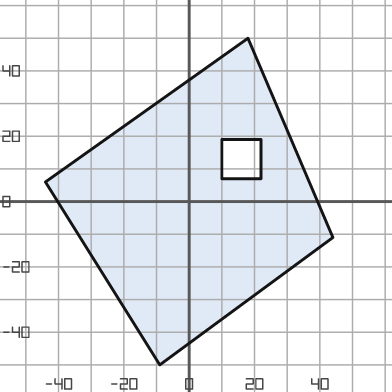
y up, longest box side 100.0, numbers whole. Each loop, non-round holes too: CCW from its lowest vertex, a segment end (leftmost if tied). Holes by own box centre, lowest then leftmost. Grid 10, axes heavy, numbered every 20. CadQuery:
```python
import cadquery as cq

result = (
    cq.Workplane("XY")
    .moveTo(-9.0, -50.0)
    .lineTo(44.0, -11.0)
    .lineTo(18.0, 50.0)
    .lineTo(-44.0, 6.0)
    .close()
    .moveTo(10.0, 7.0)
    .lineTo(22.0, 7.0)
    .lineTo(22.0, 19.0)
    .lineTo(10.0, 19.0)
    .close()
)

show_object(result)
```